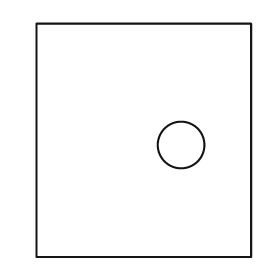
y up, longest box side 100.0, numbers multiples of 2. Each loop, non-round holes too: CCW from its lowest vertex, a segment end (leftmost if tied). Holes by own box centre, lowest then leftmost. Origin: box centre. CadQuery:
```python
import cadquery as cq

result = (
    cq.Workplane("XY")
    .moveTo(-46.0, -50.0)
    .lineTo(46.0, -50.0)
    .lineTo(46.0, 50.0)
    .lineTo(-46.0, 50.0)
    .close()
    .moveTo(16.0, -2.0)
    .circle(10.0)
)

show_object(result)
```